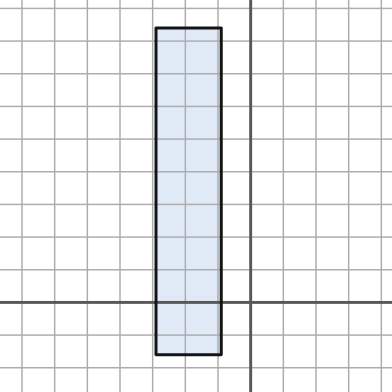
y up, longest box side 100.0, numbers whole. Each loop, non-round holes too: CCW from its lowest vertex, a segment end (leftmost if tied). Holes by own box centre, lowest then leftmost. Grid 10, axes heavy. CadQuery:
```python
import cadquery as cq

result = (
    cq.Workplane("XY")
    .moveTo(-29.0, -16.0)
    .lineTo(-9.0, -16.0)
    .lineTo(-9.0, 84.0)
    .lineTo(-29.0, 84.0)
    .close()
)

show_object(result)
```